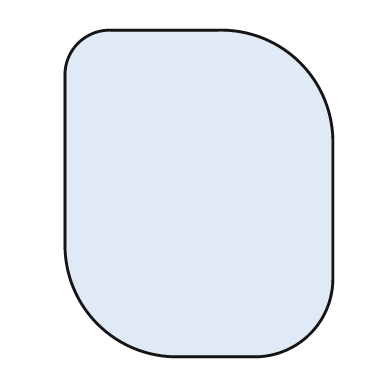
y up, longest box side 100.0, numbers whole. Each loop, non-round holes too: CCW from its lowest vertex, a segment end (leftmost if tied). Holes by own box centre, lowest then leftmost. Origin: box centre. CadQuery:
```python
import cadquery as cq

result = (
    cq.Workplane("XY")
    .moveTo(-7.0, -50.0)
    .lineTo(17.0, -50.0)
    .threePointArc((34.0, -43.0), (41.0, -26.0))
    .lineTo(41.0, 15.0)
    .threePointArc((31.0, 40.0), (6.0, 50.0))
    .lineTo(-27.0, 50.0)
    .threePointArc((-37.0, 46.0), (-41.0, 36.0))
    .lineTo(-41.0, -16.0)
    .threePointArc((-31.0, -40.0), (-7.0, -50.0))
    .close()
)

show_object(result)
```